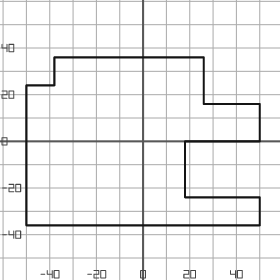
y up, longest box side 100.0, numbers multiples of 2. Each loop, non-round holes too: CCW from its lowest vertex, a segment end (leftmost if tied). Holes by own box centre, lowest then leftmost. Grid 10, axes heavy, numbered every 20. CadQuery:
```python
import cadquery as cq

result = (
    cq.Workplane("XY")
    .moveTo(-50.0, -36.0)
    .lineTo(50.0, -36.0)
    .lineTo(50.0, -24.0)
    .lineTo(18.0, -24.0)
    .lineTo(18.0, 0.0)
    .lineTo(50.0, 0.0)
    .lineTo(50.0, 16.0)
    .lineTo(26.0, 16.0)
    .lineTo(26.0, 36.0)
    .lineTo(-38.0, 36.0)
    .lineTo(-38.0, 24.0)
    .lineTo(-50.0, 24.0)
    .close()
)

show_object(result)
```